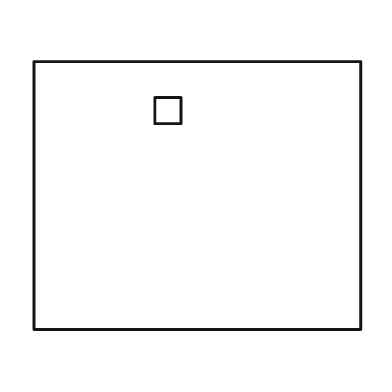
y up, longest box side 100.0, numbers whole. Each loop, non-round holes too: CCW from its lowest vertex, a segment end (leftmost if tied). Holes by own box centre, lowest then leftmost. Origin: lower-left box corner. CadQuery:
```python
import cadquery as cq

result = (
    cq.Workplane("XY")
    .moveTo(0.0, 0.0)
    .lineTo(100.0, 0.0)
    .lineTo(100.0, 82.0)
    .lineTo(0.0, 82.0)
    .close()
    .moveTo(37.0, 63.0)
    .lineTo(45.0, 63.0)
    .lineTo(45.0, 71.0)
    .lineTo(37.0, 71.0)
    .close()
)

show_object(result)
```